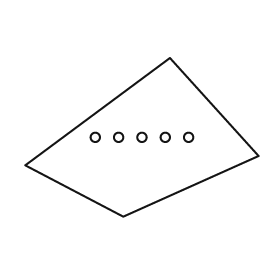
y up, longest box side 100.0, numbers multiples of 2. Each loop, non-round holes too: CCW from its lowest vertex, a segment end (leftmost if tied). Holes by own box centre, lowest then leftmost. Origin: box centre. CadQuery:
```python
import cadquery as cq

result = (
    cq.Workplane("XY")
    .moveTo(-8.0, -34.0)
    .lineTo(50.0, -8.0)
    .lineTo(12.0, 34.0)
    .lineTo(-50.0, -12.0)
    .close()
    .moveTo(-20.0, 0.0)
    .circle(2.0)
    .moveTo(-10.0, 0.0)
    .circle(2.0)
    .moveTo(0.0, 0.0)
    .circle(2.0)
    .moveTo(10.0, 0.0)
    .circle(2.0)
    .moveTo(20.0, 0.0)
    .circle(2.0)
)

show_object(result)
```